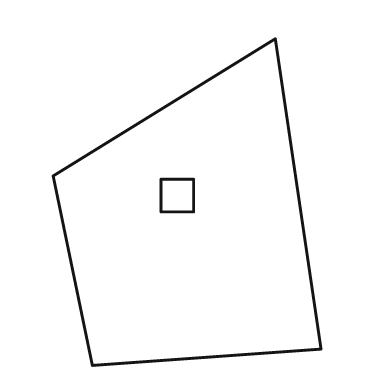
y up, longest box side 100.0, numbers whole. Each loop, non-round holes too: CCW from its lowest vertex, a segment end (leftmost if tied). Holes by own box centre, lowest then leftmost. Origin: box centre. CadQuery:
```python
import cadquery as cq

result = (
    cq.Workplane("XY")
    .moveTo(-29.0, -50.0)
    .lineTo(41.0, -45.0)
    .lineTo(27.0, 50.0)
    .lineTo(-41.0, 8.0)
    .close()
    .moveTo(-8.0, -3.0)
    .lineTo(2.0, -3.0)
    .lineTo(2.0, 7.0)
    .lineTo(-8.0, 7.0)
    .close()
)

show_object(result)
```